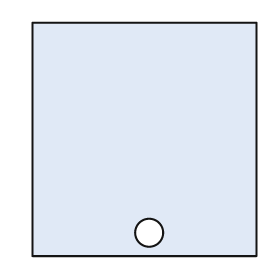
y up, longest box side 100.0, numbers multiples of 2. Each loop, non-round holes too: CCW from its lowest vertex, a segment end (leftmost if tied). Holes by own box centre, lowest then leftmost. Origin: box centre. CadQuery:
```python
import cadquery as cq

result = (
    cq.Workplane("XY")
    .moveTo(-48.0, -50.0)
    .lineTo(48.0, -50.0)
    .lineTo(48.0, 50.0)
    .lineTo(-48.0, 50.0)
    .close()
    .moveTo(2.0, -40.0)
    .circle(6.0)
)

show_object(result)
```